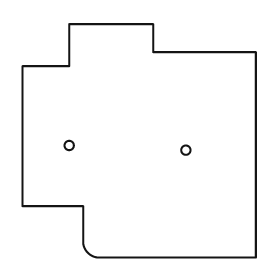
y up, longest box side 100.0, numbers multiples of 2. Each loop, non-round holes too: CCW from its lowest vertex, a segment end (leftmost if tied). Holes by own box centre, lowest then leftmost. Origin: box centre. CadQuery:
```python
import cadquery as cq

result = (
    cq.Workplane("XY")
    .moveTo(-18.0, -50.0)
    .lineTo(50.0, -50.0)
    .lineTo(50.0, 38.0)
    .lineTo(6.0, 38.0)
    .lineTo(6.0, 50.0)
    .lineTo(-30.0, 50.0)
    .lineTo(-30.0, 32.0)
    .lineTo(-50.0, 32.0)
    .lineTo(-50.0, -28.0)
    .lineTo(-24.0, -28.0)
    .lineTo(-24.0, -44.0)
    .threePointArc((-22.0, -48.0), (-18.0, -50.0))
    .close()
    .moveTo(20.0, -4.0)
    .circle(2.0)
    .moveTo(-30.0, -2.0)
    .circle(2.0)
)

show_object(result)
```